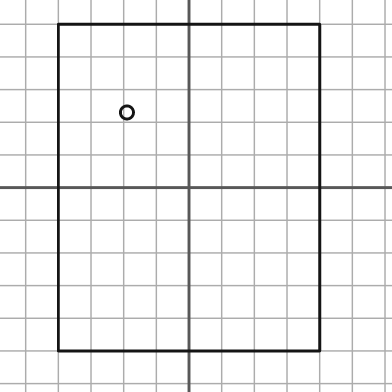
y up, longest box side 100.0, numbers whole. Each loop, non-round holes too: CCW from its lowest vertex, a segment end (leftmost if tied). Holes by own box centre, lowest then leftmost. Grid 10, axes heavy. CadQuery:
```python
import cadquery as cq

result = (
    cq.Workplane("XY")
    .moveTo(-40.0, -50.0)
    .lineTo(40.0, -50.0)
    .lineTo(40.0, 50.0)
    .lineTo(-40.0, 50.0)
    .close()
    .moveTo(-19.0, 23.0)
    .circle(2.0)
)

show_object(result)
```